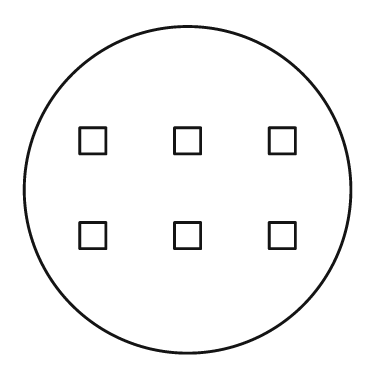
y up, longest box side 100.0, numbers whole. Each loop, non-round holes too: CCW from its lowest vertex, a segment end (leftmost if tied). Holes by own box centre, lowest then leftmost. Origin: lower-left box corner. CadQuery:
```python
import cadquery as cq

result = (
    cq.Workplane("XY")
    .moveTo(50.0, 50.0)
    .circle(50.0)
    .moveTo(17.0, 32.0)
    .lineTo(25.0, 32.0)
    .lineTo(25.0, 40.0)
    .lineTo(17.0, 40.0)
    .close()
    .moveTo(46.0, 32.0)
    .lineTo(54.0, 32.0)
    .lineTo(54.0, 40.0)
    .lineTo(46.0, 40.0)
    .close()
    .moveTo(75.0, 32.0)
    .lineTo(83.0, 32.0)
    .lineTo(83.0, 40.0)
    .lineTo(75.0, 40.0)
    .close()
    .moveTo(17.0, 61.0)
    .lineTo(25.0, 61.0)
    .lineTo(25.0, 69.0)
    .lineTo(17.0, 69.0)
    .close()
    .moveTo(46.0, 61.0)
    .lineTo(54.0, 61.0)
    .lineTo(54.0, 69.0)
    .lineTo(46.0, 69.0)
    .close()
    .moveTo(75.0, 61.0)
    .lineTo(83.0, 61.0)
    .lineTo(83.0, 69.0)
    .lineTo(75.0, 69.0)
    .close()
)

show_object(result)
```